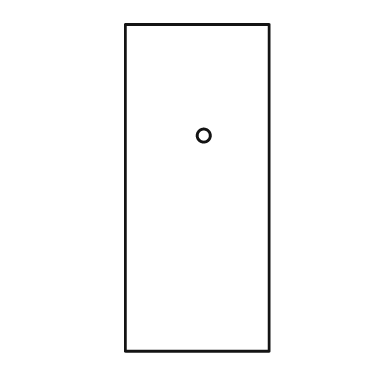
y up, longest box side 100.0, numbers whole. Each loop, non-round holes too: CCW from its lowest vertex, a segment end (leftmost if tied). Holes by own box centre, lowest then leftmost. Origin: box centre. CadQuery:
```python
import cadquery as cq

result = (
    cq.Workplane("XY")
    .moveTo(-22.0, -50.0)
    .lineTo(22.0, -50.0)
    .lineTo(22.0, 50.0)
    .lineTo(-22.0, 50.0)
    .close()
    .moveTo(2.0, 16.0)
    .circle(2.0)
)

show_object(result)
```